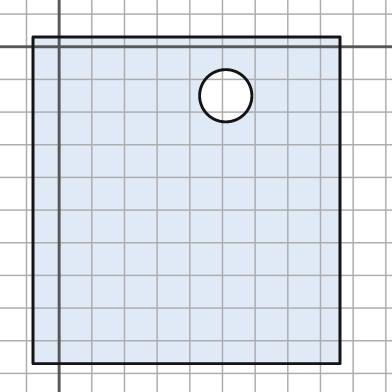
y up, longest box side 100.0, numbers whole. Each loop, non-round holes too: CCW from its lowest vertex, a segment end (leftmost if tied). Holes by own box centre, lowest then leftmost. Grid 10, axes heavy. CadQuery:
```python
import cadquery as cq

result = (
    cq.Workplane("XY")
    .moveTo(-8.0, -97.0)
    .lineTo(86.0, -97.0)
    .lineTo(86.0, 3.0)
    .lineTo(-8.0, 3.0)
    .close()
    .moveTo(51.0, -15.0)
    .circle(8.0)
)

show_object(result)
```